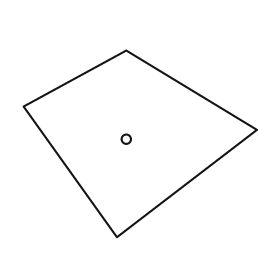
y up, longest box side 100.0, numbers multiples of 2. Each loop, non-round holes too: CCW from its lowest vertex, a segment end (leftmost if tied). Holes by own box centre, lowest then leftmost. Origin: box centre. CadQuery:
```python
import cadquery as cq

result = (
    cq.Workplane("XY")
    .moveTo(-10.0, -40.0)
    .lineTo(50.0, 6.0)
    .lineTo(-6.0, 40.0)
    .lineTo(-50.0, 16.0)
    .close()
    .moveTo(-6.0, 2.0)
    .circle(2.0)
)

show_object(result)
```